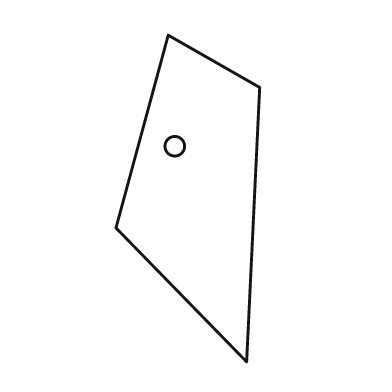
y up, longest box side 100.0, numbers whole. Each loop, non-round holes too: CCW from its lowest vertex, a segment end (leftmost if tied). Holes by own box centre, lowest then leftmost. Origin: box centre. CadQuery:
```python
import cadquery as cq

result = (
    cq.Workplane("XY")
    .moveTo(18.0, -50.0)
    .lineTo(22.0, 34.0)
    .lineTo(-6.0, 50.0)
    .lineTo(-22.0, -9.0)
    .close()
    .moveTo(-4.0, 16.0)
    .circle(3.0)
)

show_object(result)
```